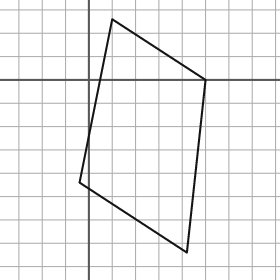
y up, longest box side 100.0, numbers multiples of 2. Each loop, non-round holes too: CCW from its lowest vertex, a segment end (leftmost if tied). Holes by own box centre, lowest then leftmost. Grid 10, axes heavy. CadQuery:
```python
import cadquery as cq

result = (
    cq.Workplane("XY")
    .moveTo(42.0, -74.0)
    .lineTo(50.0, 0.0)
    .lineTo(10.0, 26.0)
    .lineTo(-4.0, -44.0)
    .close()
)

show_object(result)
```